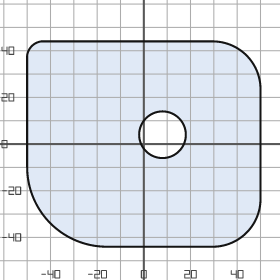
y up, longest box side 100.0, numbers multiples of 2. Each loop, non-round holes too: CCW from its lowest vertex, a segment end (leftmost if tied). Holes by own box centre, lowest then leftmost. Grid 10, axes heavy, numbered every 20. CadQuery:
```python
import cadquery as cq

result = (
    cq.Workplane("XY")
    .moveTo(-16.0, -44.0)
    .lineTo(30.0, -44.0)
    .threePointArc((44.0, -38.0), (50.0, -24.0))
    .lineTo(50.0, 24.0)
    .threePointArc((44.0, 38.0), (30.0, 44.0))
    .lineTo(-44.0, 44.0)
    .threePointArc((-48.0, 42.0), (-50.0, 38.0))
    .lineTo(-50.0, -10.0)
    .threePointArc((-40.0, -34.0), (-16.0, -44.0))
    .close()
    .moveTo(8.0, 4.0)
    .circle(10.0)
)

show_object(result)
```